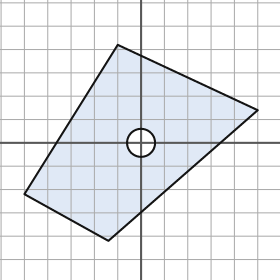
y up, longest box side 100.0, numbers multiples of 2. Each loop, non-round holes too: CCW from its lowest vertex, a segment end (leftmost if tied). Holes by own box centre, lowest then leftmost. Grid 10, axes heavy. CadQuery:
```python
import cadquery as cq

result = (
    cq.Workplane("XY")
    .moveTo(-14.0, -42.0)
    .lineTo(50.0, 14.0)
    .lineTo(-10.0, 42.0)
    .lineTo(-50.0, -22.0)
    .close()
    .moveTo(0.0, 0.0)
    .circle(6.0)
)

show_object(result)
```